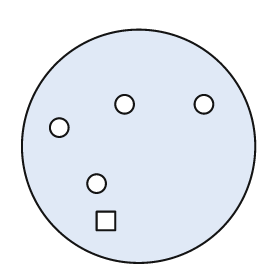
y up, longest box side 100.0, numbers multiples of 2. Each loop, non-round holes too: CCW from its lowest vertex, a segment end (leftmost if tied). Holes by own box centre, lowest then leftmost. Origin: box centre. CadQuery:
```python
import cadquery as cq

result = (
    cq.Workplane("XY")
    .moveTo(0.0, 0.0)
    .circle(50.0)
    .moveTo(-18.0, -36.0)
    .lineTo(-10.0, -36.0)
    .lineTo(-10.0, -28.0)
    .lineTo(-18.0, -28.0)
    .close()
    .moveTo(-18.0, -16.0)
    .circle(4.0)
    .moveTo(-34.0, 8.0)
    .circle(4.0)
    .moveTo(-6.0, 18.0)
    .circle(4.0)
    .moveTo(28.0, 18.0)
    .circle(4.0)
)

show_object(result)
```